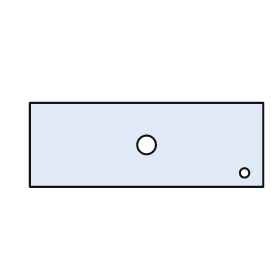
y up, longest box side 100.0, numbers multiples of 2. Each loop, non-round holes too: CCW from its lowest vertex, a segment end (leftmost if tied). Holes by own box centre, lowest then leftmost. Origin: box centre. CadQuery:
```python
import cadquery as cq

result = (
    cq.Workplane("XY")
    .moveTo(-50.0, -18.0)
    .lineTo(50.0, -18.0)
    .lineTo(50.0, 18.0)
    .lineTo(-50.0, 18.0)
    .close()
    .moveTo(42.0, -12.0)
    .circle(2.0)
    .moveTo(0.0, 0.0)
    .circle(4.0)
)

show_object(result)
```